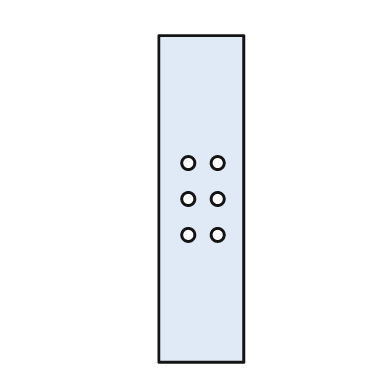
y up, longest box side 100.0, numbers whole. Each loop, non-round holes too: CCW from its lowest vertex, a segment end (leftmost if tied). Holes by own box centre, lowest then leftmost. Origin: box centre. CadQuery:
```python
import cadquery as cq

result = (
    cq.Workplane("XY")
    .moveTo(-13.0, -50.0)
    .lineTo(13.0, -50.0)
    .lineTo(13.0, 50.0)
    .lineTo(-13.0, 50.0)
    .close()
    .moveTo(-4.0, -11.0)
    .circle(2.0)
    .moveTo(5.0, -11.0)
    .circle(2.0)
    .moveTo(-4.0, 0.0)
    .circle(2.0)
    .moveTo(5.0, 0.0)
    .circle(2.0)
    .moveTo(-4.0, 11.0)
    .circle(2.0)
    .moveTo(5.0, 11.0)
    .circle(2.0)
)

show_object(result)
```